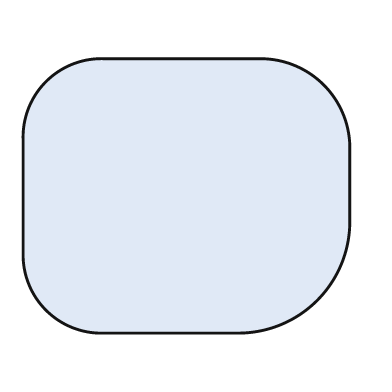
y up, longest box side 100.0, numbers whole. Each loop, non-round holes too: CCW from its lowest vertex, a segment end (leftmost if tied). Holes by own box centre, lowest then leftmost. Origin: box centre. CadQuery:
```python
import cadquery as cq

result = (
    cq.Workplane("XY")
    .moveTo(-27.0, -42.0)
    .lineTo(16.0, -42.0)
    .threePointArc((40.0, -32.0), (50.0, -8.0))
    .lineTo(50.0, 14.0)
    .threePointArc((42.0, 34.0), (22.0, 42.0))
    .lineTo(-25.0, 42.0)
    .threePointArc((-43.0, 35.0), (-50.0, 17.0))
    .lineTo(-50.0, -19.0)
    .threePointArc((-43.0, -35.0), (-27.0, -42.0))
    .close()
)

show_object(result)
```